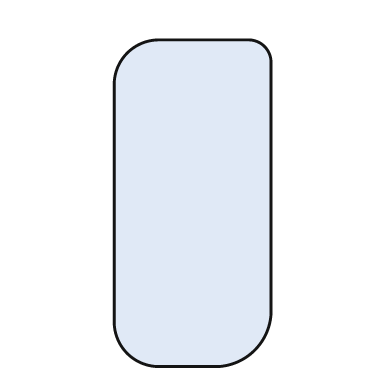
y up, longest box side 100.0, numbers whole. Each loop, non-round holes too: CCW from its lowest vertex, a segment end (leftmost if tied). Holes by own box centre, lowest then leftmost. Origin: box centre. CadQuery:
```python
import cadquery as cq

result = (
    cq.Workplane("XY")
    .moveTo(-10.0, -50.0)
    .lineTo(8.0, -50.0)
    .threePointArc((19.0, -45.0), (24.0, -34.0))
    .lineTo(24.0, 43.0)
    .threePointArc((22.0, 48.0), (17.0, 50.0))
    .lineTo(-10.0, 50.0)
    .threePointArc((-20.0, 46.0), (-24.0, 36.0))
    .lineTo(-24.0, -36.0)
    .threePointArc((-20.0, -46.0), (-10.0, -50.0))
    .close()
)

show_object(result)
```